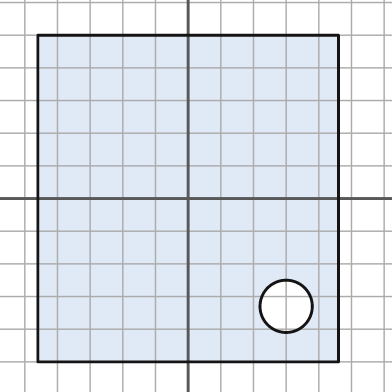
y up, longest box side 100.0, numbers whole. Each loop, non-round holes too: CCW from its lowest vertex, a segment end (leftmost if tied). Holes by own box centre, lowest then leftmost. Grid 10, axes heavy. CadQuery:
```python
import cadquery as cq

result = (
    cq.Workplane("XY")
    .moveTo(-46.0, -50.0)
    .lineTo(46.0, -50.0)
    .lineTo(46.0, 50.0)
    .lineTo(-46.0, 50.0)
    .close()
    .moveTo(30.0, -33.0)
    .circle(8.0)
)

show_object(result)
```